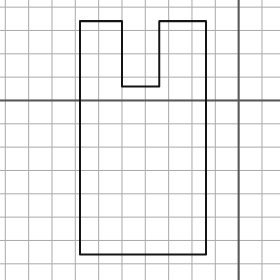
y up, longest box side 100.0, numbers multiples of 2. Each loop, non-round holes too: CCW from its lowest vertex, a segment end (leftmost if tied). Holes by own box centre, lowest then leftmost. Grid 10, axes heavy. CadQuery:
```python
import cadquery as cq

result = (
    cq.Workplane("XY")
    .moveTo(-68.0, -66.0)
    .lineTo(-14.0, -66.0)
    .lineTo(-14.0, 34.0)
    .lineTo(-34.0, 34.0)
    .lineTo(-34.0, 6.0)
    .lineTo(-50.0, 6.0)
    .lineTo(-50.0, 34.0)
    .lineTo(-68.0, 34.0)
    .close()
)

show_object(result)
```